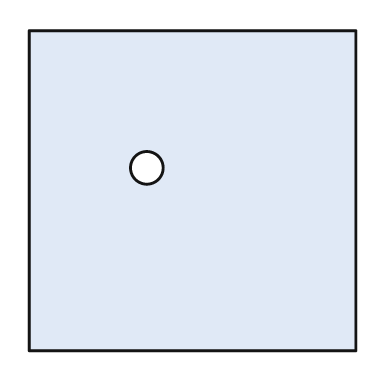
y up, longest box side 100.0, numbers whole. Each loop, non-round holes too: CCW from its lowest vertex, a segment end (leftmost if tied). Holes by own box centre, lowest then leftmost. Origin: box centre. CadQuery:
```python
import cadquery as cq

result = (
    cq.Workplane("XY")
    .moveTo(-50.0, -49.0)
    .lineTo(50.0, -49.0)
    .lineTo(50.0, 49.0)
    .lineTo(-50.0, 49.0)
    .close()
    .moveTo(-14.0, 7.0)
    .circle(5.0)
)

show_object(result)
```